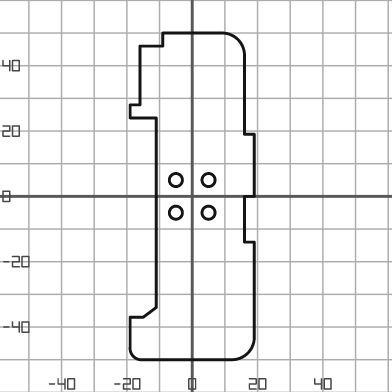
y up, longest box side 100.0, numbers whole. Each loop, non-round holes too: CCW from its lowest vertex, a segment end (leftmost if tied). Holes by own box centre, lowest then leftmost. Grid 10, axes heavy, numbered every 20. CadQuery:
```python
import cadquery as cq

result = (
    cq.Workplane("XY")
    .moveTo(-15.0, -50.0)
    .lineTo(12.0, -50.0)
    .threePointArc((17.0, -48.0), (19.0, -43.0))
    .lineTo(19.0, -14.0)
    .lineTo(16.0, -14.0)
    .lineTo(16.0, 0.0)
    .lineTo(19.0, 0.0)
    .lineTo(19.0, 19.0)
    .lineTo(16.0, 19.0)
    .lineTo(16.0, 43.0)
    .threePointArc((14.0, 48.0), (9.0, 50.0))
    .lineTo(-9.0, 50.0)
    .lineTo(-9.0, 46.0)
    .lineTo(-16.0, 46.0)
    .lineTo(-16.0, 28.0)
    .lineTo(-19.0, 28.0)
    .lineTo(-19.0, 24.0)
    .lineTo(-11.0, 24.0)
    .lineTo(-11.0, -34.0)
    .lineTo(-15.0, -37.0)
    .lineTo(-19.0, -37.0)
    .lineTo(-19.0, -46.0)
    .threePointArc((-18.0, -49.0), (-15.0, -50.0))
    .close()
    .moveTo(-5.0, -5.0)
    .circle(2.0)
    .moveTo(5.0, -5.0)
    .circle(2.0)
    .moveTo(-5.0, 5.0)
    .circle(2.0)
    .moveTo(5.0, 5.0)
    .circle(2.0)
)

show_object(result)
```